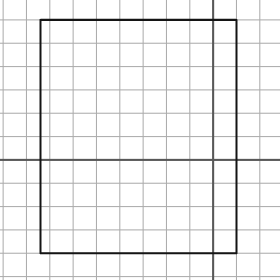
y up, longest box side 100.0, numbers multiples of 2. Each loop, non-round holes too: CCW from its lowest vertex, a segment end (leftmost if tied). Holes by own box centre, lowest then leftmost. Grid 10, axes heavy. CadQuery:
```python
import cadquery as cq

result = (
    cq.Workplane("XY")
    .moveTo(-74.0, -40.0)
    .lineTo(10.0, -40.0)
    .lineTo(10.0, 60.0)
    .lineTo(-74.0, 60.0)
    .close()
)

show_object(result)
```